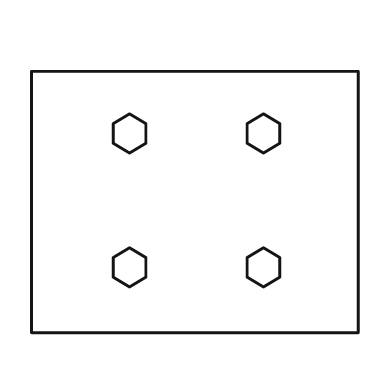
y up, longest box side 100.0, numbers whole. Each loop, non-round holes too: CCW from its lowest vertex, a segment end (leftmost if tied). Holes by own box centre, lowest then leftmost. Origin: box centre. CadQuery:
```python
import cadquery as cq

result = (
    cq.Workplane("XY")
    .moveTo(-50.0, -40.0)
    .lineTo(50.0, -40.0)
    .lineTo(50.0, 40.0)
    .lineTo(-50.0, 40.0)
    .close()
    .moveTo(-20.0, -26.0)
    .lineTo(-15.0, -23.0)
    .lineTo(-15.0, -17.0)
    .lineTo(-20.0, -14.0)
    .lineTo(-25.0, -17.0)
    .lineTo(-25.0, -23.0)
    .close()
    .moveTo(21.0, -26.0)
    .lineTo(26.0, -23.0)
    .lineTo(26.0, -17.0)
    .lineTo(21.0, -14.0)
    .lineTo(16.0, -17.0)
    .lineTo(16.0, -23.0)
    .close()
    .moveTo(-20.0, 15.0)
    .lineTo(-15.0, 18.0)
    .lineTo(-15.0, 24.0)
    .lineTo(-20.0, 27.0)
    .lineTo(-25.0, 24.0)
    .lineTo(-25.0, 18.0)
    .close()
    .moveTo(21.0, 15.0)
    .lineTo(26.0, 18.0)
    .lineTo(26.0, 24.0)
    .lineTo(21.0, 27.0)
    .lineTo(16.0, 24.0)
    .lineTo(16.0, 18.0)
    .close()
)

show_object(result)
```